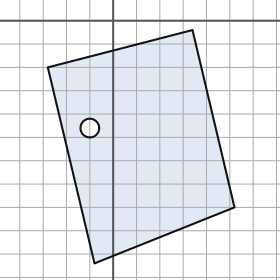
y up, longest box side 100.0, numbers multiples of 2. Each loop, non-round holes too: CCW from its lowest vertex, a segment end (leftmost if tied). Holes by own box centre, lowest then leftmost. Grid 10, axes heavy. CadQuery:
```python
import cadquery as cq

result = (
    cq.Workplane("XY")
    .moveTo(-8.0, -104.0)
    .lineTo(52.0, -80.0)
    .lineTo(34.0, -4.0)
    .lineTo(-28.0, -20.0)
    .close()
    .moveTo(-10.0, -46.0)
    .circle(4.0)
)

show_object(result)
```